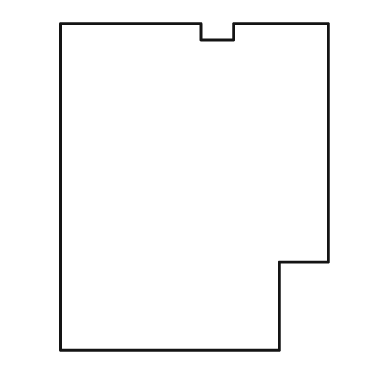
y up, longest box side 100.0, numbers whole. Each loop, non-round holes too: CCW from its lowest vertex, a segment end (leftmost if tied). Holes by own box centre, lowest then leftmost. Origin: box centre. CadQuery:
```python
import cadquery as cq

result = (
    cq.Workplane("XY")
    .moveTo(-41.0, -50.0)
    .lineTo(26.0, -50.0)
    .lineTo(26.0, -23.0)
    .lineTo(41.0, -23.0)
    .lineTo(41.0, 50.0)
    .lineTo(12.0, 50.0)
    .lineTo(12.0, 45.0)
    .lineTo(2.0, 45.0)
    .lineTo(2.0, 50.0)
    .lineTo(-41.0, 50.0)
    .close()
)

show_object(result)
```